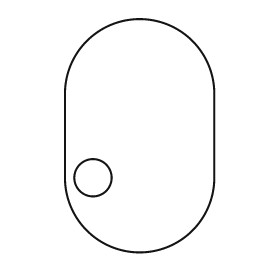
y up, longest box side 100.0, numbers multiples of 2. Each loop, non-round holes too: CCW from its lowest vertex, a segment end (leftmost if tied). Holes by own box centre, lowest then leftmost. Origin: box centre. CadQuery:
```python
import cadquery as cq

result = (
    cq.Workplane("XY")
    .moveTo(-32.0, -18.0)
    .threePointArc((0.0, -50.0), (32.0, -18.0))
    .lineTo(32.0, 18.0)
    .threePointArc((0.0, 50.0), (-32.0, 18.0))
    .close()
    .moveTo(-20.0, -18.0)
    .circle(8.0)
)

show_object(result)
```